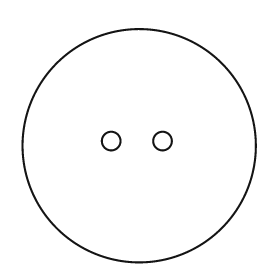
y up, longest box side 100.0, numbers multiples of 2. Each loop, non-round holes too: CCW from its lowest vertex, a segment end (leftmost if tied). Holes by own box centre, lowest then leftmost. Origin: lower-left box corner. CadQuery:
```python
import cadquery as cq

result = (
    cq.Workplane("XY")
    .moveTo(50.0, 50.0)
    .circle(50.0)
    .moveTo(38.0, 52.0)
    .circle(4.0)
    .moveTo(60.0, 52.0)
    .circle(4.0)
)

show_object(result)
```